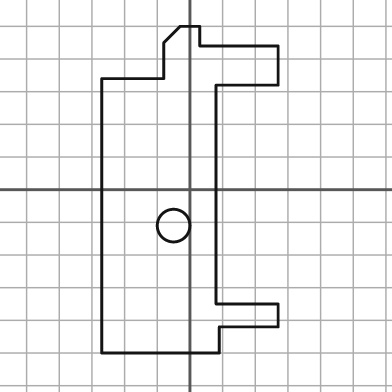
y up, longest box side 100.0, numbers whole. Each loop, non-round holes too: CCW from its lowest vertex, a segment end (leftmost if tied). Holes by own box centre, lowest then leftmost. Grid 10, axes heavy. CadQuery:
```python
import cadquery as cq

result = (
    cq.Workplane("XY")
    .moveTo(-27.0, -50.0)
    .lineTo(9.0, -50.0)
    .lineTo(9.0, -42.0)
    .lineTo(27.0, -42.0)
    .lineTo(27.0, -35.0)
    .lineTo(8.0, -35.0)
    .lineTo(8.0, 32.0)
    .lineTo(27.0, 32.0)
    .lineTo(27.0, 44.0)
    .lineTo(3.0, 44.0)
    .lineTo(3.0, 50.0)
    .lineTo(-3.0, 50.0)
    .lineTo(-8.0, 45.0)
    .lineTo(-8.0, 34.0)
    .lineTo(-27.0, 34.0)
    .close()
    .moveTo(-5.0, -11.0)
    .circle(5.0)
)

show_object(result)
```